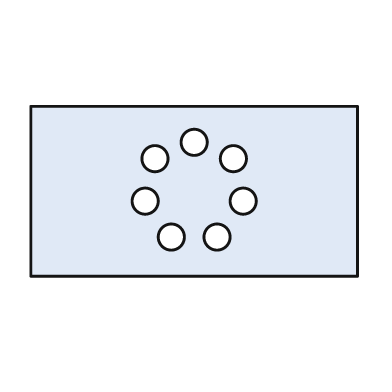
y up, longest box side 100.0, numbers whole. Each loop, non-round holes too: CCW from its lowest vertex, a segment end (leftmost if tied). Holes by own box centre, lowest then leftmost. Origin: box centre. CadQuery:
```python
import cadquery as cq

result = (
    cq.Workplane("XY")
    .moveTo(-50.0, -26.0)
    .lineTo(50.0, -26.0)
    .lineTo(50.0, 26.0)
    .lineTo(-50.0, 26.0)
    .close()
    .moveTo(-7.0, -14.0)
    .circle(4.0)
    .moveTo(7.0, -14.0)
    .circle(4.0)
    .moveTo(-15.0, -3.0)
    .circle(4.0)
    .moveTo(15.0, -3.0)
    .circle(4.0)
    .moveTo(-12.0, 10.0)
    .circle(4.0)
    .moveTo(12.0, 10.0)
    .circle(4.0)
    .moveTo(0.0, 15.0)
    .circle(4.0)
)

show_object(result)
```